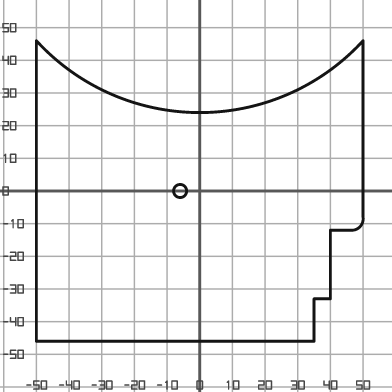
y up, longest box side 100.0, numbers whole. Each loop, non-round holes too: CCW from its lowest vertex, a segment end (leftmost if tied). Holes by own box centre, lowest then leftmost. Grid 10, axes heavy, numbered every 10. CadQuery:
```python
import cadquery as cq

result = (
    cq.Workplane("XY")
    .moveTo(-50.0, -46.0)
    .lineTo(35.0, -46.0)
    .lineTo(35.0, -33.0)
    .lineTo(40.0, -33.0)
    .lineTo(40.0, -12.0)
    .lineTo(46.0, -12.0)
    .threePointArc((49.0, -11.0), (50.0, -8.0))
    .lineTo(50.0, 46.0)
    .threePointArc((0.0, 24.0), (-50.0, 46.0))
    .close()
    .moveTo(-6.0, 0.0)
    .circle(2.0)
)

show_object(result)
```